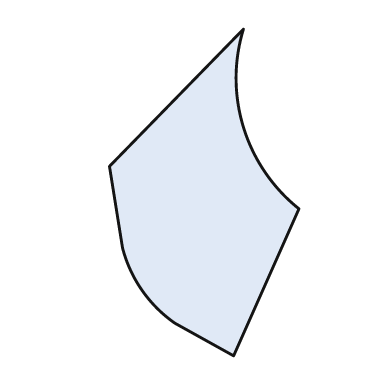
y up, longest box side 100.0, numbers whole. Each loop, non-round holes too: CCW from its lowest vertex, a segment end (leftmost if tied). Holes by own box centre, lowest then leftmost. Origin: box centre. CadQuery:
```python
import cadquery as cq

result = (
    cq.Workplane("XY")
    .moveTo(9.0, -50.0)
    .lineTo(29.0, -5.0)
    .threePointArc((12.0, 20.0), (12.0, 50.0))
    .lineTo(-29.0, 8.0)
    .lineTo(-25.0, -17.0)
    .threePointArc((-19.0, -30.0), (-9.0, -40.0))
    .close()
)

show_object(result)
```